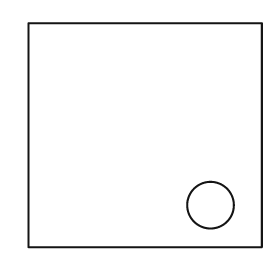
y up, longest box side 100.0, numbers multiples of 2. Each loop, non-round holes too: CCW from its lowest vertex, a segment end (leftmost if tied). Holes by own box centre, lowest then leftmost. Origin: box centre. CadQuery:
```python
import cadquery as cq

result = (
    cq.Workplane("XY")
    .moveTo(-50.0, -48.0)
    .lineTo(50.0, -48.0)
    .lineTo(50.0, 48.0)
    .lineTo(-50.0, 48.0)
    .close()
    .moveTo(28.0, -30.0)
    .circle(10.0)
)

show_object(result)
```